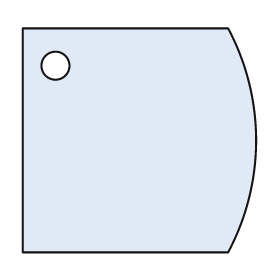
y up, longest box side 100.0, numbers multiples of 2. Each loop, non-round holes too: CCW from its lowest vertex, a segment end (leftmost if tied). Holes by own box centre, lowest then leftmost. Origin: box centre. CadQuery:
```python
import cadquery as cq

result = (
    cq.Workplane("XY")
    .moveTo(-50.0, -48.0)
    .lineTo(38.0, -48.0)
    .threePointArc((50.0, 0.0), (38.0, 48.0))
    .lineTo(-50.0, 48.0)
    .close()
    .moveTo(-36.0, 32.0)
    .circle(6.0)
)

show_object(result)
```